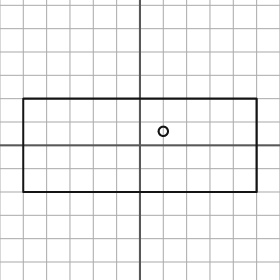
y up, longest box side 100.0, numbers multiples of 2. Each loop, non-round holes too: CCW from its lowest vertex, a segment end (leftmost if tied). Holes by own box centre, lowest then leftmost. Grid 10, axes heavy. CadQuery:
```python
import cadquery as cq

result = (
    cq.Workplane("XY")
    .moveTo(-50.0, -20.0)
    .lineTo(50.0, -20.0)
    .lineTo(50.0, 20.0)
    .lineTo(-50.0, 20.0)
    .close()
    .moveTo(10.0, 6.0)
    .circle(2.0)
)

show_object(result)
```